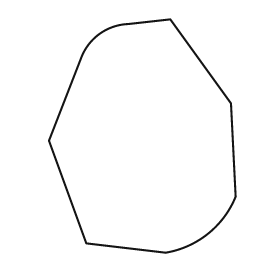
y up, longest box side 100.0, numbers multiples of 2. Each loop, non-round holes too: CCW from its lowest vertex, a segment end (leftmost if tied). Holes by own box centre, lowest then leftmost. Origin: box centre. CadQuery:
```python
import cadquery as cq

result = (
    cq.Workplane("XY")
    .moveTo(10.0, -50.0)
    .threePointArc((28.0, -42.0), (40.0, -26.0))
    .lineTo(38.0, 14.0)
    .lineTo(12.0, 50.0)
    .lineTo(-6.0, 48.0)
    .threePointArc((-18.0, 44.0), (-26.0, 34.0))
    .lineTo(-40.0, -2.0)
    .lineTo(-24.0, -46.0)
    .close()
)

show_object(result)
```